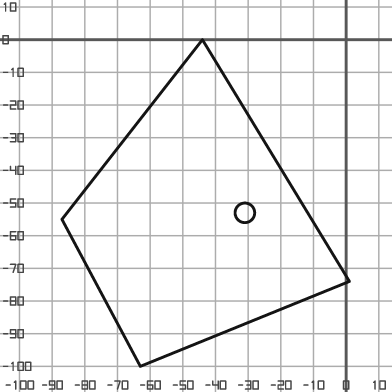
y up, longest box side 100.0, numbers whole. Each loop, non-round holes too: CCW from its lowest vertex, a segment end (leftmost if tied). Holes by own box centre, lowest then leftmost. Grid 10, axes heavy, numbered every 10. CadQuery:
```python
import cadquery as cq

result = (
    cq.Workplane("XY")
    .moveTo(-63.0, -100.0)
    .lineTo(1.0, -74.0)
    .lineTo(-44.0, 0.0)
    .lineTo(-87.0, -55.0)
    .close()
    .moveTo(-31.0, -53.0)
    .circle(3.0)
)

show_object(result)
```